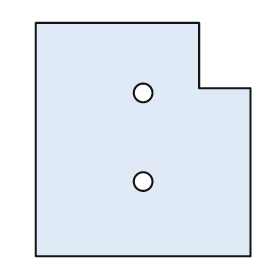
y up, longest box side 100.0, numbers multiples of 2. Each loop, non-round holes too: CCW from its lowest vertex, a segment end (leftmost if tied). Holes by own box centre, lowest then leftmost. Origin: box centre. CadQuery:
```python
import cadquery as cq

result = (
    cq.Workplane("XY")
    .moveTo(-46.0, -50.0)
    .lineTo(46.0, -50.0)
    .lineTo(46.0, 22.0)
    .lineTo(24.0, 22.0)
    .lineTo(24.0, 50.0)
    .lineTo(-46.0, 50.0)
    .close()
    .moveTo(0.0, -18.0)
    .circle(4.0)
    .moveTo(0.0, 20.0)
    .circle(4.0)
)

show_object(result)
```